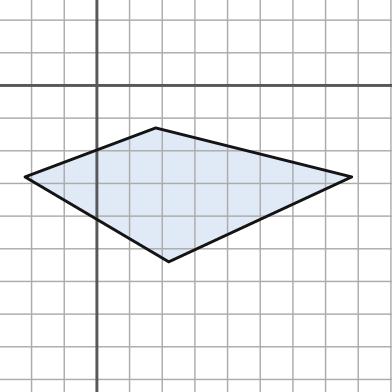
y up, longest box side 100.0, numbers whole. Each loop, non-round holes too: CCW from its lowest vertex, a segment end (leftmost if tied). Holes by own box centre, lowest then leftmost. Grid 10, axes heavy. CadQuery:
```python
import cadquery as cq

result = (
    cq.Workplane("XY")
    .moveTo(22.0, -54.0)
    .lineTo(78.0, -28.0)
    .lineTo(18.0, -13.0)
    .lineTo(-22.0, -28.0)
    .close()
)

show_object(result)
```